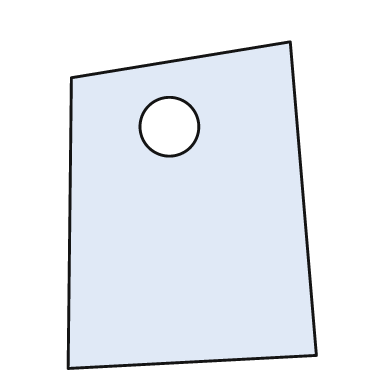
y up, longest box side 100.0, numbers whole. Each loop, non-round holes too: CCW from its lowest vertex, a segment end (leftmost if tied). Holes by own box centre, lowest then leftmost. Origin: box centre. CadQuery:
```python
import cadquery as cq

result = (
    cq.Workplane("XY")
    .moveTo(-38.0, -50.0)
    .lineTo(38.0, -46.0)
    .lineTo(30.0, 50.0)
    .lineTo(-37.0, 39.0)
    .close()
    .moveTo(-7.0, 24.0)
    .circle(9.0)
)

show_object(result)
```